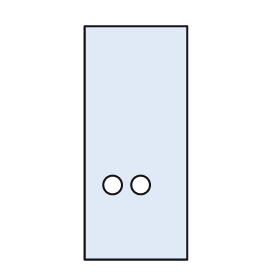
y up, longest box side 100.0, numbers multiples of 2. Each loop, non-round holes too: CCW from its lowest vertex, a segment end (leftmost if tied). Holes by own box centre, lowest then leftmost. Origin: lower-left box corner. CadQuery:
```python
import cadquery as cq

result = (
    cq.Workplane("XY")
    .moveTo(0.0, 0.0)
    .lineTo(44.0, 0.0)
    .lineTo(44.0, 100.0)
    .lineTo(0.0, 100.0)
    .close()
    .moveTo(12.0, 32.0)
    .circle(4.0)
    .moveTo(24.0, 32.0)
    .circle(4.0)
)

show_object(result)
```